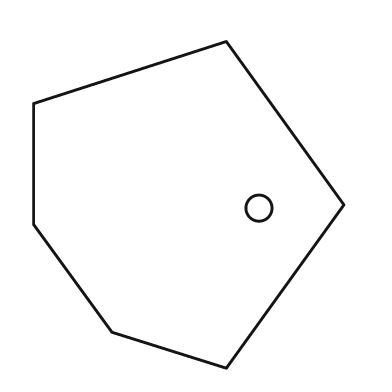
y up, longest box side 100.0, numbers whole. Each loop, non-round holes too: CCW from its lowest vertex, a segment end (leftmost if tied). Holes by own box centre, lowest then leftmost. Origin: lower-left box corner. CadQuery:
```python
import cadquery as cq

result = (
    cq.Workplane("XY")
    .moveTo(59.0, 0.0)
    .lineTo(95.0, 50.0)
    .lineTo(59.0, 100.0)
    .lineTo(0.0, 81.0)
    .lineTo(0.0, 44.0)
    .lineTo(24.0, 11.0)
    .close()
    .moveTo(69.0, 49.0)
    .circle(4.0)
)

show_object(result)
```